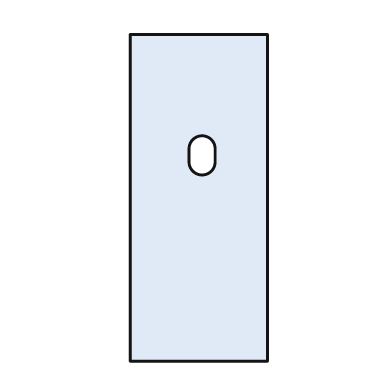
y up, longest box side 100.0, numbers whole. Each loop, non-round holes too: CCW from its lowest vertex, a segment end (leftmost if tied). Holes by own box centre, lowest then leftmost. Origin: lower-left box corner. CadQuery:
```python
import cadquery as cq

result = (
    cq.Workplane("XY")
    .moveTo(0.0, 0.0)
    .lineTo(42.0, 0.0)
    .lineTo(42.0, 100.0)
    .lineTo(0.0, 100.0)
    .close()
    .moveTo(18.0, 61.0)
    .threePointArc((22.0, 57.0), (26.0, 61.0))
    .lineTo(26.0, 65.0)
    .threePointArc((22.0, 69.0), (18.0, 65.0))
    .close()
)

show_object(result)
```